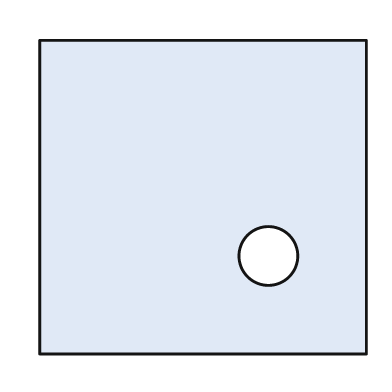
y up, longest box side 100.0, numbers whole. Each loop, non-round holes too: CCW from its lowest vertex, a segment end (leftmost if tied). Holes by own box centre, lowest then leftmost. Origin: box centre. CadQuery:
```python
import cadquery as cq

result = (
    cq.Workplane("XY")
    .moveTo(-50.0, -48.0)
    .lineTo(50.0, -48.0)
    .lineTo(50.0, 48.0)
    .lineTo(-50.0, 48.0)
    .close()
    .moveTo(20.0, -18.0)
    .circle(9.0)
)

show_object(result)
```